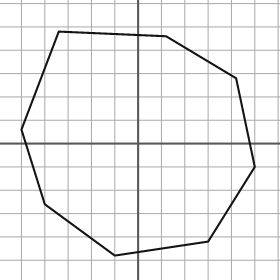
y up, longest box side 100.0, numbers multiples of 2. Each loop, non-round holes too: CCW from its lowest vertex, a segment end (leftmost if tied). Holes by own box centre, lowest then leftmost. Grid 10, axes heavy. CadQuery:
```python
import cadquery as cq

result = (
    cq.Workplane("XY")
    .moveTo(-10.0, -48.0)
    .lineTo(30.0, -42.0)
    .lineTo(50.0, -10.0)
    .lineTo(42.0, 28.0)
    .lineTo(12.0, 46.0)
    .lineTo(-34.0, 48.0)
    .lineTo(-50.0, 6.0)
    .lineTo(-40.0, -26.0)
    .close()
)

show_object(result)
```